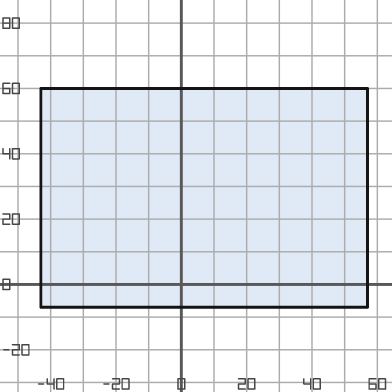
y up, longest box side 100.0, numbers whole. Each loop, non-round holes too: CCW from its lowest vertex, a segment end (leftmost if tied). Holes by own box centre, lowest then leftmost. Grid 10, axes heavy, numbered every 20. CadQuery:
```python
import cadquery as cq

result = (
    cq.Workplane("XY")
    .moveTo(-43.0, -7.0)
    .lineTo(57.0, -7.0)
    .lineTo(57.0, 60.0)
    .lineTo(-43.0, 60.0)
    .close()
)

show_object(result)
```